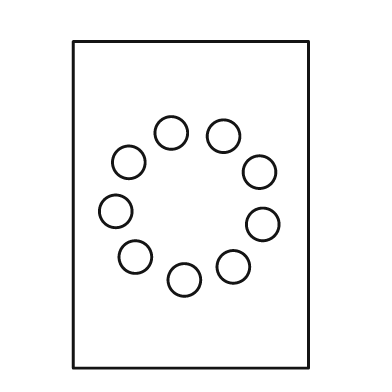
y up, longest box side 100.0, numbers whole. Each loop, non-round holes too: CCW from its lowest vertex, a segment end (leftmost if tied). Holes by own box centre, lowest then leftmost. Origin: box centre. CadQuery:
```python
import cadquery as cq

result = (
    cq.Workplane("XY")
    .moveTo(-36.0, -50.0)
    .lineTo(36.0, -50.0)
    .lineTo(36.0, 50.0)
    .lineTo(-36.0, 50.0)
    .close()
    .moveTo(-2.0, -23.0)
    .circle(5.0)
    .moveTo(13.0, -19.0)
    .circle(5.0)
    .moveTo(-17.0, -16.0)
    .circle(5.0)
    .moveTo(22.0, -6.0)
    .circle(5.0)
    .moveTo(-23.0, -2.0)
    .circle(5.0)
    .moveTo(21.0, 10.0)
    .circle(5.0)
    .moveTo(-19.0, 13.0)
    .circle(5.0)
    .moveTo(10.0, 21.0)
    .circle(5.0)
    .moveTo(-6.0, 22.0)
    .circle(5.0)
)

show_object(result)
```